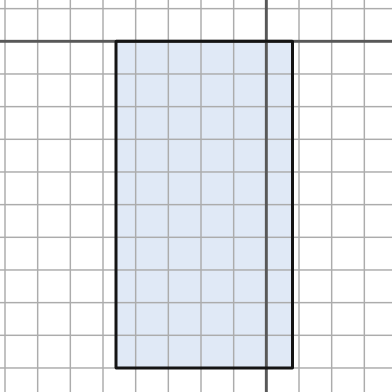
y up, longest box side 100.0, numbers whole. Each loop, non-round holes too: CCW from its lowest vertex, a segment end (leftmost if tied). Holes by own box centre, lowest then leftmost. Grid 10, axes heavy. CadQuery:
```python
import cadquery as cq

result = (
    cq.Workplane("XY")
    .moveTo(-46.0, -100.0)
    .lineTo(8.0, -100.0)
    .lineTo(8.0, 0.0)
    .lineTo(-46.0, 0.0)
    .close()
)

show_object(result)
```